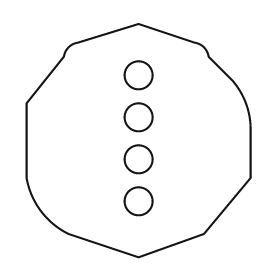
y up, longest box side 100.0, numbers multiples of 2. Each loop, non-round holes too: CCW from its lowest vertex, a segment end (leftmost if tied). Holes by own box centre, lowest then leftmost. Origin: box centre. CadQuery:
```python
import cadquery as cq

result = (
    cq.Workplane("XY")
    .moveTo(0.0, -50.0)
    .lineTo(28.0, -40.0)
    .lineTo(48.0, -16.0)
    .lineTo(48.0, 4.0)
    .threePointArc((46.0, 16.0), (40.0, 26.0))
    .lineTo(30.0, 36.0)
    .threePointArc((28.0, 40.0), (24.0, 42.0))
    .lineTo(0.0, 50.0)
    .lineTo(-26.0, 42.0)
    .threePointArc((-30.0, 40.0), (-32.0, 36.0))
    .lineTo(-48.0, 16.0)
    .lineTo(-48.0, -16.0)
    .threePointArc((-42.0, -30.0), (-30.0, -40.0))
    .close()
    .moveTo(0.0, -26.0)
    .circle(6.0)
    .moveTo(0.0, -8.0)
    .circle(6.0)
    .moveTo(0.0, 10.0)
    .circle(6.0)
    .moveTo(0.0, 28.0)
    .circle(6.0)
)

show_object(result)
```